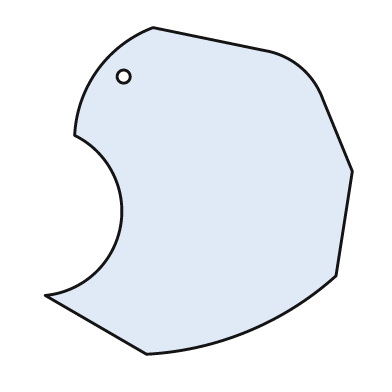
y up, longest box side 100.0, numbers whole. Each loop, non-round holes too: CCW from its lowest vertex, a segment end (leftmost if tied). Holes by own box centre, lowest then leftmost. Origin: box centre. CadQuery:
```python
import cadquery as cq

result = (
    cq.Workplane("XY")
    .moveTo(-16.0, -50.0)
    .threePointArc((15.0, -43.0), (42.0, -26.0))
    .lineTo(47.0, 6.0)
    .lineTo(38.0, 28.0)
    .threePointArc((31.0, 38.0), (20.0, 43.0))
    .lineTo(-14.0, 50.0)
    .threePointArc((-31.0, 37.0), (-38.0, 17.0))
    .threePointArc((-24.0, -11.0), (-47.0, -32.0))
    .close()
    .moveTo(-23.0, 35.0)
    .circle(2.0)
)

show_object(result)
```